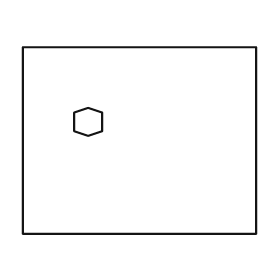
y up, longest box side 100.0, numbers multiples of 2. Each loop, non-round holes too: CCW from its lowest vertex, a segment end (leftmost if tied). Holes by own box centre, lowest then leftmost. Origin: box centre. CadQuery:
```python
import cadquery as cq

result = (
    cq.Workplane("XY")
    .moveTo(-50.0, -40.0)
    .lineTo(50.0, -40.0)
    .lineTo(50.0, 40.0)
    .lineTo(-50.0, 40.0)
    .close()
    .moveTo(-22.0, 2.0)
    .lineTo(-16.0, 4.0)
    .lineTo(-16.0, 12.0)
    .lineTo(-22.0, 14.0)
    .lineTo(-28.0, 12.0)
    .lineTo(-28.0, 4.0)
    .close()
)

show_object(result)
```